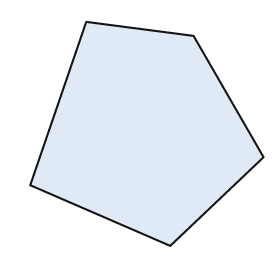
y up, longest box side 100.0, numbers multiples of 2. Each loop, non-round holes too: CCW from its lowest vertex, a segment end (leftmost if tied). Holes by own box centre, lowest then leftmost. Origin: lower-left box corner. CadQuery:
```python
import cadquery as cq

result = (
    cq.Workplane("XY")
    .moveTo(60.0, 0.0)
    .lineTo(100.0, 38.0)
    .lineTo(70.0, 90.0)
    .lineTo(24.0, 96.0)
    .lineTo(0.0, 26.0)
    .close()
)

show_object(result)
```